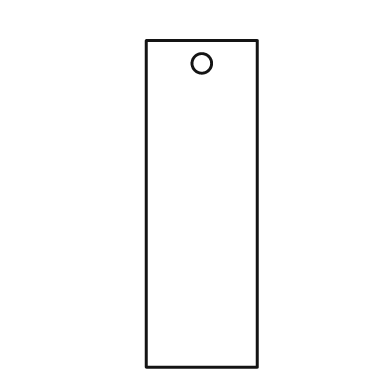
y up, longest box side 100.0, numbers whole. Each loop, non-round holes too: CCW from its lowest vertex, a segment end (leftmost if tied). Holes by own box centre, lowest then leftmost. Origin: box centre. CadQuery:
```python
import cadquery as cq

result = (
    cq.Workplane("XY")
    .moveTo(-17.0, -50.0)
    .lineTo(17.0, -50.0)
    .lineTo(17.0, 50.0)
    .lineTo(-17.0, 50.0)
    .close()
    .moveTo(0.0, 43.0)
    .circle(3.0)
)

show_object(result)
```